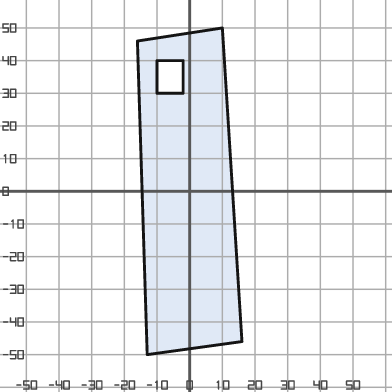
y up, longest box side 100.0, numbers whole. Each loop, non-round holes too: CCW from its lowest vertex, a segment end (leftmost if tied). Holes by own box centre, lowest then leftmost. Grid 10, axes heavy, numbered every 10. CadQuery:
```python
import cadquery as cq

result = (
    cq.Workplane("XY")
    .moveTo(-13.0, -50.0)
    .lineTo(16.0, -46.0)
    .lineTo(10.0, 50.0)
    .lineTo(-16.0, 46.0)
    .close()
    .moveTo(-10.0, 30.0)
    .lineTo(-2.0, 30.0)
    .lineTo(-2.0, 40.0)
    .lineTo(-10.0, 40.0)
    .close()
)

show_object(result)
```